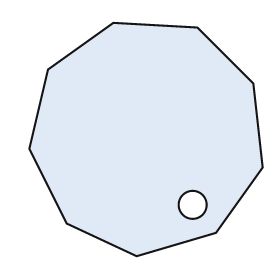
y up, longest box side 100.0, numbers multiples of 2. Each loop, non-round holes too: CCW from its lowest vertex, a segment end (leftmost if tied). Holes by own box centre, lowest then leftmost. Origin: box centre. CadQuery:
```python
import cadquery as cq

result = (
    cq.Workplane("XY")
    .moveTo(-4.0, -50.0)
    .lineTo(30.0, -40.0)
    .lineTo(50.0, -12.0)
    .lineTo(46.0, 24.0)
    .lineTo(22.0, 48.0)
    .lineTo(-14.0, 50.0)
    .lineTo(-42.0, 30.0)
    .lineTo(-50.0, -4.0)
    .lineTo(-34.0, -36.0)
    .close()
    .moveTo(20.0, -28.0)
    .circle(6.0)
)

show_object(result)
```